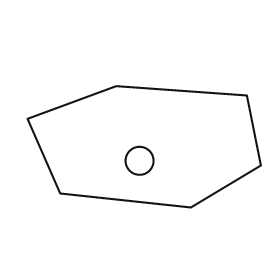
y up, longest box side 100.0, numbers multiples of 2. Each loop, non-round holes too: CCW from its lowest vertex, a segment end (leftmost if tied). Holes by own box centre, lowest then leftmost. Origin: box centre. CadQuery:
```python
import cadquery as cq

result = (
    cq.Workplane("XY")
    .moveTo(20.0, -26.0)
    .lineTo(50.0, -8.0)
    .lineTo(44.0, 22.0)
    .lineTo(-12.0, 26.0)
    .lineTo(-50.0, 12.0)
    .lineTo(-36.0, -20.0)
    .close()
    .moveTo(-2.0, -6.0)
    .circle(6.0)
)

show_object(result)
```